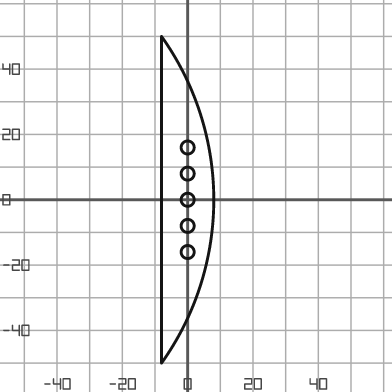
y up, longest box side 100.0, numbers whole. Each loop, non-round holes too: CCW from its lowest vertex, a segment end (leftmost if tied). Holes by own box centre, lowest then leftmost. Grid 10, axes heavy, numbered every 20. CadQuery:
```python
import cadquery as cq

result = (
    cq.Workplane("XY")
    .moveTo(-8.0, -50.0)
    .threePointArc((8.0, 0.0), (-8.0, 50.0))
    .close()
    .moveTo(0.0, -16.0)
    .circle(2.0)
    .moveTo(0.0, -8.0)
    .circle(2.0)
    .moveTo(0.0, 0.0)
    .circle(2.0)
    .moveTo(0.0, 8.0)
    .circle(2.0)
    .moveTo(0.0, 16.0)
    .circle(2.0)
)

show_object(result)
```